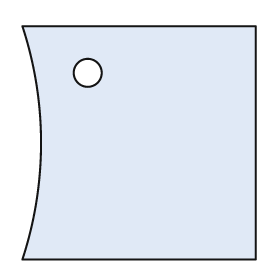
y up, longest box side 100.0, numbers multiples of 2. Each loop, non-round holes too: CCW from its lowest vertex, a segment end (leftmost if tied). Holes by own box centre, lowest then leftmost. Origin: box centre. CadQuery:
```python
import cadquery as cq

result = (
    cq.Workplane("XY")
    .moveTo(-50.0, -50.0)
    .lineTo(50.0, -50.0)
    .lineTo(50.0, 50.0)
    .lineTo(-50.0, 50.0)
    .threePointArc((-42.0, 0.0), (-50.0, -50.0))
    .close()
    .moveTo(-22.0, 30.0)
    .circle(6.0)
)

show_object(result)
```